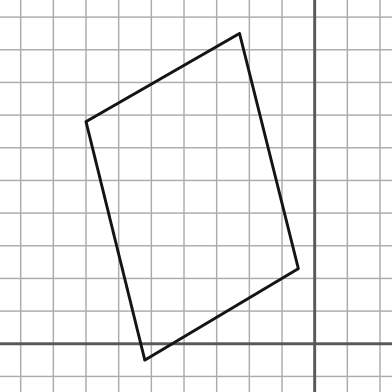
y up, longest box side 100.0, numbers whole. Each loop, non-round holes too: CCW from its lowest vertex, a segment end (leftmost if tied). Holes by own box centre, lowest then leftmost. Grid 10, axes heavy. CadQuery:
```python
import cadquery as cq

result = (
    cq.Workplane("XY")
    .moveTo(-52.0, -5.0)
    .lineTo(-5.0, 23.0)
    .lineTo(-23.0, 95.0)
    .lineTo(-70.0, 68.0)
    .close()
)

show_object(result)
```